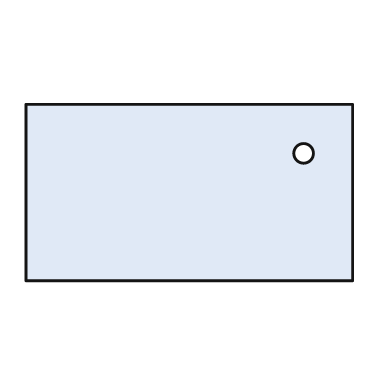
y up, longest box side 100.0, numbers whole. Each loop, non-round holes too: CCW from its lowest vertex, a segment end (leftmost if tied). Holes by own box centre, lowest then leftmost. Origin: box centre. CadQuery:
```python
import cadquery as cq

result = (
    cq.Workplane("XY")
    .moveTo(-50.0, -27.0)
    .lineTo(50.0, -27.0)
    .lineTo(50.0, 27.0)
    .lineTo(-50.0, 27.0)
    .close()
    .moveTo(35.0, 12.0)
    .circle(3.0)
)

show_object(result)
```